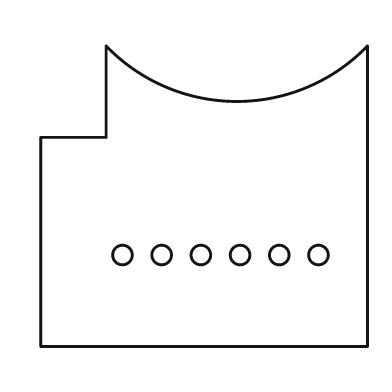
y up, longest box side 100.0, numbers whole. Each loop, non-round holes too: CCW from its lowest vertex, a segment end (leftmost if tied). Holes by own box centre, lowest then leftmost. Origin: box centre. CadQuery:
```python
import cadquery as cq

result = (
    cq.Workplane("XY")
    .moveTo(-50.0, -46.0)
    .lineTo(50.0, -46.0)
    .lineTo(50.0, 46.0)
    .threePointArc((10.0, 29.0), (-30.0, 46.0))
    .lineTo(-30.0, 18.0)
    .lineTo(-50.0, 18.0)
    .close()
    .moveTo(-25.0, -18.0)
    .circle(3.0)
    .moveTo(-13.0, -18.0)
    .circle(3.0)
    .moveTo(-1.0, -18.0)
    .circle(3.0)
    .moveTo(11.0, -18.0)
    .circle(3.0)
    .moveTo(23.0, -18.0)
    .circle(3.0)
    .moveTo(35.0, -18.0)
    .circle(3.0)
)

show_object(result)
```